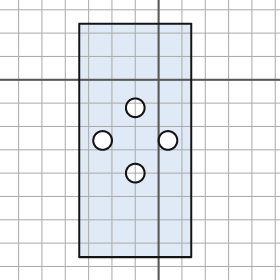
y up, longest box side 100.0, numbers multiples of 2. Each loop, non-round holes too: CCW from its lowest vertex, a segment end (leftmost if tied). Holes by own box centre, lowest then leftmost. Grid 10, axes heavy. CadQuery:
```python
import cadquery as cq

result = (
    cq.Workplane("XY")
    .moveTo(-34.0, -76.0)
    .lineTo(14.0, -76.0)
    .lineTo(14.0, 24.0)
    .lineTo(-34.0, 24.0)
    .close()
    .moveTo(-10.0, -40.0)
    .circle(4.0)
    .moveTo(-24.0, -26.0)
    .circle(4.0)
    .moveTo(4.0, -26.0)
    .circle(4.0)
    .moveTo(-10.0, -12.0)
    .circle(4.0)
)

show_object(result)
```